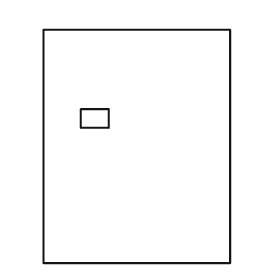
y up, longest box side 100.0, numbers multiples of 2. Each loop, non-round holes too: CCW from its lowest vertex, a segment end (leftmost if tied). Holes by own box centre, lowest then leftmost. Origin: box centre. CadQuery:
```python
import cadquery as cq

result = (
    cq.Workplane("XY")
    .moveTo(-40.0, -50.0)
    .lineTo(40.0, -50.0)
    .lineTo(40.0, 50.0)
    .lineTo(-40.0, 50.0)
    .close()
    .moveTo(-24.0, 8.0)
    .lineTo(-12.0, 8.0)
    .lineTo(-12.0, 16.0)
    .lineTo(-24.0, 16.0)
    .close()
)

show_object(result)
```